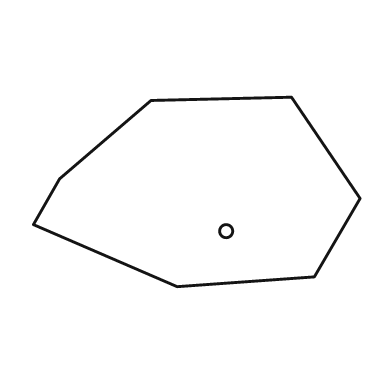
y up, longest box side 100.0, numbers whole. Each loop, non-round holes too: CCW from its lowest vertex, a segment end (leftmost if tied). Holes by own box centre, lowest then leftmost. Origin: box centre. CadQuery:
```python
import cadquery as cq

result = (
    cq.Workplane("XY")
    .moveTo(-6.0, -29.0)
    .lineTo(36.0, -26.0)
    .lineTo(50.0, -2.0)
    .lineTo(29.0, 29.0)
    .lineTo(-14.0, 28.0)
    .lineTo(-42.0, 4.0)
    .lineTo(-50.0, -10.0)
    .close()
    .moveTo(9.0, -12.0)
    .circle(2.0)
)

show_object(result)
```